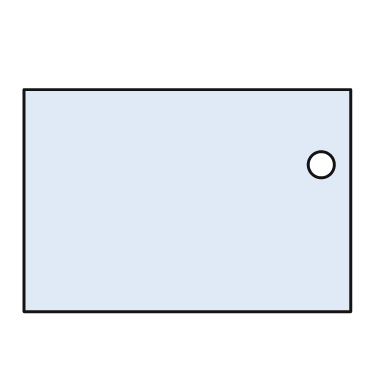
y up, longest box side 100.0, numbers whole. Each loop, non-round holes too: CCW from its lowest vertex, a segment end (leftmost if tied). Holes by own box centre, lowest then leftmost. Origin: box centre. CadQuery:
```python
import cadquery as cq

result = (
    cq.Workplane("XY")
    .moveTo(-50.0, -34.0)
    .lineTo(50.0, -34.0)
    .lineTo(50.0, 34.0)
    .lineTo(-50.0, 34.0)
    .close()
    .moveTo(41.0, 11.0)
    .circle(4.0)
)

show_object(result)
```